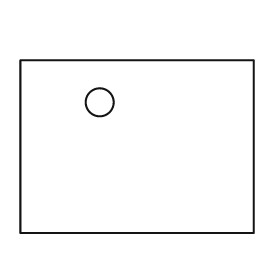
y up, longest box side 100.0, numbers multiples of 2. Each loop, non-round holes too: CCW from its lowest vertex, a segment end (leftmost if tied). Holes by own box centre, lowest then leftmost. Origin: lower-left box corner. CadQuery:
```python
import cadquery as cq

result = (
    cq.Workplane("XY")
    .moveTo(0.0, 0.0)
    .lineTo(100.0, 0.0)
    .lineTo(100.0, 74.0)
    .lineTo(0.0, 74.0)
    .close()
    .moveTo(34.0, 56.0)
    .circle(6.0)
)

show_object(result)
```